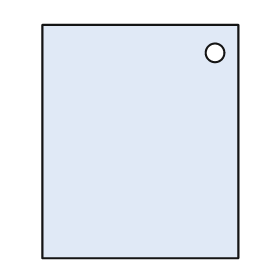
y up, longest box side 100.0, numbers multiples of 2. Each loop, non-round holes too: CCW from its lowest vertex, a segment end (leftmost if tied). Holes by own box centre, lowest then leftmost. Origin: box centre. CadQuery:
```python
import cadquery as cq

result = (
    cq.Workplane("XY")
    .moveTo(-42.0, -50.0)
    .lineTo(42.0, -50.0)
    .lineTo(42.0, 50.0)
    .lineTo(-42.0, 50.0)
    .close()
    .moveTo(32.0, 38.0)
    .circle(4.0)
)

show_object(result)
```